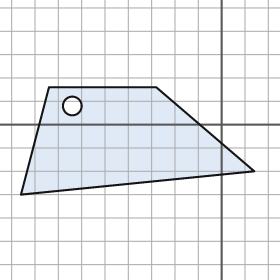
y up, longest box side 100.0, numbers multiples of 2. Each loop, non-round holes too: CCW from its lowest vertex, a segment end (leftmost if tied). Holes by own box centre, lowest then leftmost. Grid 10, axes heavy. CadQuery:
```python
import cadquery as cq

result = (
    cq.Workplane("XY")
    .moveTo(-86.0, -30.0)
    .lineTo(14.0, -20.0)
    .lineTo(-28.0, 16.0)
    .lineTo(-74.0, 16.0)
    .close()
    .moveTo(-64.0, 8.0)
    .circle(4.0)
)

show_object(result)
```